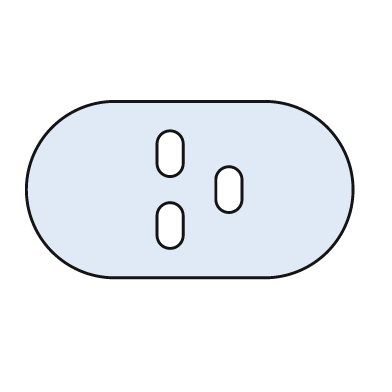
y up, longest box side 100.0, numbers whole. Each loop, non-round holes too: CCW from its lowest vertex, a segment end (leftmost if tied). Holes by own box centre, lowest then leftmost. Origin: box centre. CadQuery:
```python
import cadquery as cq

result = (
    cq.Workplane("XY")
    .moveTo(-23.0, -27.0)
    .lineTo(23.0, -27.0)
    .threePointArc((50.0, 0.0), (23.0, 27.0))
    .lineTo(-23.0, 27.0)
    .threePointArc((-50.0, 0.0), (-23.0, -27.0))
    .close()
    .moveTo(-10.0, -14.0)
    .threePointArc((-6.0, -18.0), (-2.0, -14.0))
    .lineTo(-2.0, -8.0)
    .threePointArc((-6.0, -4.0), (-10.0, -8.0))
    .close()
    .moveTo(8.0, -3.0)
    .threePointArc((12.0, -7.0), (16.0, -3.0))
    .lineTo(16.0, 3.0)
    .threePointArc((12.0, 7.0), (8.0, 3.0))
    .close()
    .moveTo(-10.0, 8.0)
    .threePointArc((-6.0, 4.0), (-2.0, 8.0))
    .lineTo(-2.0, 14.0)
    .threePointArc((-6.0, 18.0), (-10.0, 14.0))
    .close()
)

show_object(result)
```